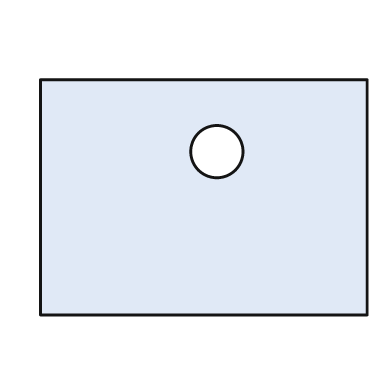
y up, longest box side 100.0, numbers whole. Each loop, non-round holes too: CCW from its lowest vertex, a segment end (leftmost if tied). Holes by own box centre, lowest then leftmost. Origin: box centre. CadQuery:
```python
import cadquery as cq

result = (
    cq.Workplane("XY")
    .moveTo(-50.0, -36.0)
    .lineTo(50.0, -36.0)
    .lineTo(50.0, 36.0)
    .lineTo(-50.0, 36.0)
    .close()
    .moveTo(4.0, 14.0)
    .circle(8.0)
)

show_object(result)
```